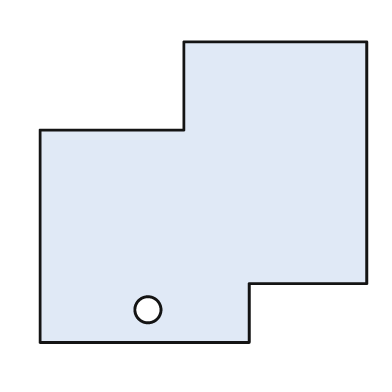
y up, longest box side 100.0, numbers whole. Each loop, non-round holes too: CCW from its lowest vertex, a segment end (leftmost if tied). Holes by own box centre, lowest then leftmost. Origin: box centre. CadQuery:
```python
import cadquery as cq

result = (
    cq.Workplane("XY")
    .moveTo(-50.0, -46.0)
    .lineTo(14.0, -46.0)
    .lineTo(14.0, -28.0)
    .lineTo(50.0, -28.0)
    .lineTo(50.0, 46.0)
    .lineTo(-6.0, 46.0)
    .lineTo(-6.0, 19.0)
    .lineTo(-50.0, 19.0)
    .close()
    .moveTo(-17.0, -36.0)
    .circle(4.0)
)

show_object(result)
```